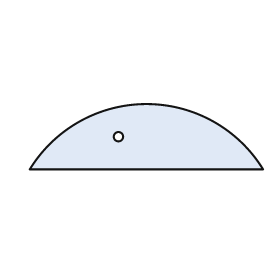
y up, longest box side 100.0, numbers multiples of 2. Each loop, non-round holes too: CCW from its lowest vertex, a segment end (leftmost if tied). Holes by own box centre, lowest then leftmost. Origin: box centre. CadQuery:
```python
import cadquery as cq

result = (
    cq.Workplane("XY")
    .moveTo(-50.0, -14.0)
    .lineTo(50.0, -14.0)
    .threePointArc((0.0, 14.0), (-50.0, -14.0))
    .close()
    .moveTo(-12.0, 0.0)
    .circle(2.0)
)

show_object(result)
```